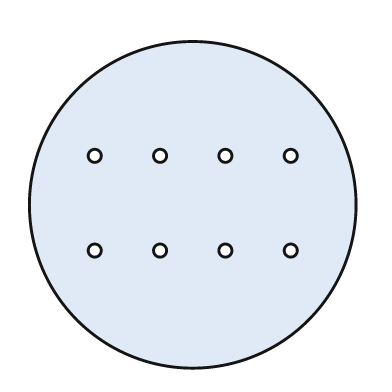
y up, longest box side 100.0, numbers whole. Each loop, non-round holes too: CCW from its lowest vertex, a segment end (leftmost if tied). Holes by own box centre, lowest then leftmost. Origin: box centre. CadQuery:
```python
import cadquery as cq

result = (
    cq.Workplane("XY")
    .moveTo(0.0, 0.0)
    .circle(50.0)
    .moveTo(-30.0, -14.0)
    .circle(2.0)
    .moveTo(-10.0, -14.0)
    .circle(2.0)
    .moveTo(10.0, -14.0)
    .circle(2.0)
    .moveTo(30.0, -14.0)
    .circle(2.0)
    .moveTo(-30.0, 15.0)
    .circle(2.0)
    .moveTo(-10.0, 15.0)
    .circle(2.0)
    .moveTo(10.0, 15.0)
    .circle(2.0)
    .moveTo(30.0, 15.0)
    .circle(2.0)
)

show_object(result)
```